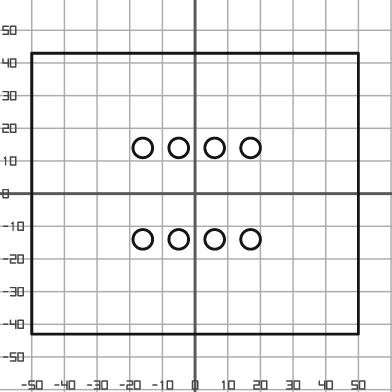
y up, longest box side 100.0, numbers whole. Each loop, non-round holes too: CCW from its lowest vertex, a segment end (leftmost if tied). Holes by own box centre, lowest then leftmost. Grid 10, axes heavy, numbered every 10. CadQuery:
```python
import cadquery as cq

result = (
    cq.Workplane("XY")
    .moveTo(-50.0, -43.0)
    .lineTo(50.0, -43.0)
    .lineTo(50.0, 43.0)
    .lineTo(-50.0, 43.0)
    .close()
    .moveTo(-16.0, -14.0)
    .circle(3.0)
    .moveTo(-5.0, -14.0)
    .circle(3.0)
    .moveTo(6.0, -14.0)
    .circle(3.0)
    .moveTo(17.0, -14.0)
    .circle(3.0)
    .moveTo(-16.0, 14.0)
    .circle(3.0)
    .moveTo(-5.0, 14.0)
    .circle(3.0)
    .moveTo(6.0, 14.0)
    .circle(3.0)
    .moveTo(17.0, 14.0)
    .circle(3.0)
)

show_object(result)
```